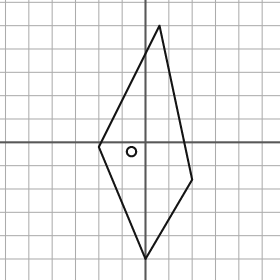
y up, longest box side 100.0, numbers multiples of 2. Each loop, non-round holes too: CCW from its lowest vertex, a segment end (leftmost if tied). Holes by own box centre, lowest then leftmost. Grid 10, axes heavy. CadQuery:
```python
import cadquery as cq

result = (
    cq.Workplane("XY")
    .moveTo(0.0, -50.0)
    .lineTo(20.0, -16.0)
    .lineTo(6.0, 50.0)
    .lineTo(-20.0, -2.0)
    .close()
    .moveTo(-6.0, -4.0)
    .circle(2.0)
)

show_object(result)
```